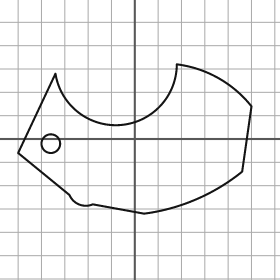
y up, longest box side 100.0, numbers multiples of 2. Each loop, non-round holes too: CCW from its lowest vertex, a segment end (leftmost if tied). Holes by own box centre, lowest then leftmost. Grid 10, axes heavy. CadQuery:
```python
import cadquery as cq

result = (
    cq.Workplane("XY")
    .moveTo(4.0, -32.0)
    .threePointArc((26.0, -26.0), (46.0, -14.0))
    .lineTo(50.0, 14.0)
    .threePointArc((36.0, 26.0), (18.0, 32.0))
    .threePointArc((-6.0, 6.0), (-34.0, 28.0))
    .lineTo(-50.0, -6.0)
    .lineTo(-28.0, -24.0)
    .threePointArc((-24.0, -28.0), (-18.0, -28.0))
    .close()
    .moveTo(-36.0, -2.0)
    .circle(4.0)
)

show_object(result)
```